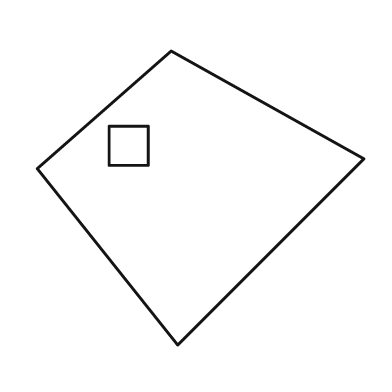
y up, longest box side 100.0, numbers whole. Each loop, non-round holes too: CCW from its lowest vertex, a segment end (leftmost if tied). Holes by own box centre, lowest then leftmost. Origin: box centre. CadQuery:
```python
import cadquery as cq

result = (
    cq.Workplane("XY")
    .moveTo(-7.0, -45.0)
    .lineTo(50.0, 12.0)
    .lineTo(-9.0, 45.0)
    .lineTo(-50.0, 9.0)
    .close()
    .moveTo(-28.0, 10.0)
    .lineTo(-16.0, 10.0)
    .lineTo(-16.0, 22.0)
    .lineTo(-28.0, 22.0)
    .close()
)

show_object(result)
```